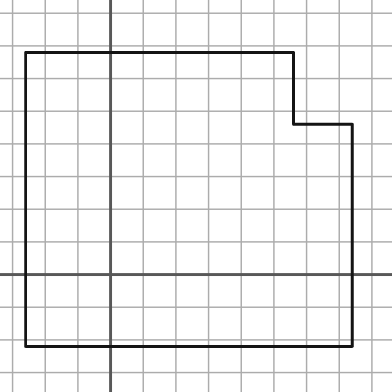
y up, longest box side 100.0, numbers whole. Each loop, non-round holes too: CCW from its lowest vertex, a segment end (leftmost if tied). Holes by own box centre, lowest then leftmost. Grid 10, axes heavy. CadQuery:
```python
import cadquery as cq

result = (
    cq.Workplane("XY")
    .moveTo(-26.0, -22.0)
    .lineTo(74.0, -22.0)
    .lineTo(74.0, 46.0)
    .lineTo(56.0, 46.0)
    .lineTo(56.0, 68.0)
    .lineTo(-26.0, 68.0)
    .close()
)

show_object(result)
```